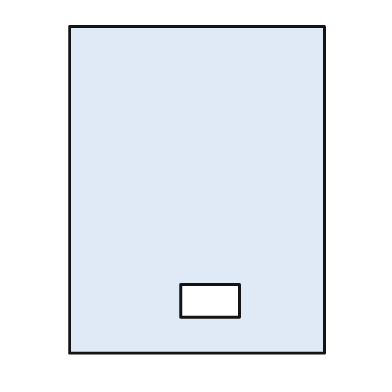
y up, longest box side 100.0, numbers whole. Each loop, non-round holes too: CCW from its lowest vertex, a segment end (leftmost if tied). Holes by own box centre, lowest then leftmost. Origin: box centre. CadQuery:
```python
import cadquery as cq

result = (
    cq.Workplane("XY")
    .moveTo(-39.0, -50.0)
    .lineTo(39.0, -50.0)
    .lineTo(39.0, 50.0)
    .lineTo(-39.0, 50.0)
    .close()
    .moveTo(-5.0, -39.0)
    .lineTo(13.0, -39.0)
    .lineTo(13.0, -29.0)
    .lineTo(-5.0, -29.0)
    .close()
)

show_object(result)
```